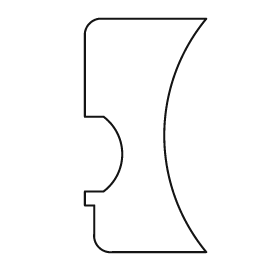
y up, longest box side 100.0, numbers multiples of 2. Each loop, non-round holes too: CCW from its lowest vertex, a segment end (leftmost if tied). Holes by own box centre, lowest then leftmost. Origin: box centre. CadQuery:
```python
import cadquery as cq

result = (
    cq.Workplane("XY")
    .moveTo(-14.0, -50.0)
    .lineTo(26.0, -50.0)
    .threePointArc((8.0, 0.0), (26.0, 50.0))
    .lineTo(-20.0, 50.0)
    .threePointArc((-24.0, 48.0), (-26.0, 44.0))
    .lineTo(-26.0, 8.0)
    .lineTo(-18.0, 8.0)
    .threePointArc((-10.0, -8.0), (-18.0, -24.0))
    .lineTo(-26.0, -24.0)
    .lineTo(-26.0, -30.0)
    .lineTo(-22.0, -30.0)
    .lineTo(-22.0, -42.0)
    .threePointArc((-20.0, -48.0), (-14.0, -50.0))
    .close()
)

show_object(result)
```